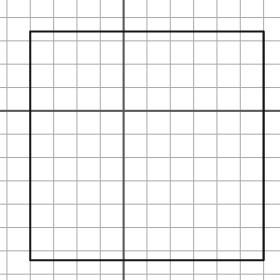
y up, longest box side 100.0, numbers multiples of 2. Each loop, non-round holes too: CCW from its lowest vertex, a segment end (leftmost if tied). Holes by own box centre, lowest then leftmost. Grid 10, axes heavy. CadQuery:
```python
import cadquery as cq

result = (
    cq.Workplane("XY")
    .moveTo(-40.0, -64.0)
    .lineTo(60.0, -64.0)
    .lineTo(60.0, 34.0)
    .lineTo(-40.0, 34.0)
    .close()
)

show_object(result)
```